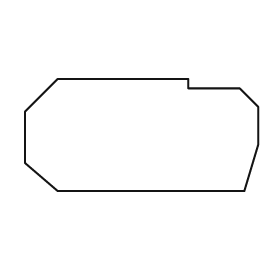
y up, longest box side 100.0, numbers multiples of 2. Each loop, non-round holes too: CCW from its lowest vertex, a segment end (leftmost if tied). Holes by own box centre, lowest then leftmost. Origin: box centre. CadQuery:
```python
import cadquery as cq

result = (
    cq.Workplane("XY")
    .moveTo(-36.0, -24.0)
    .lineTo(44.0, -24.0)
    .lineTo(50.0, -4.0)
    .lineTo(50.0, 12.0)
    .lineTo(42.0, 20.0)
    .lineTo(20.0, 20.0)
    .lineTo(20.0, 24.0)
    .lineTo(-36.0, 24.0)
    .lineTo(-50.0, 10.0)
    .lineTo(-50.0, -12.0)
    .close()
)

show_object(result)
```